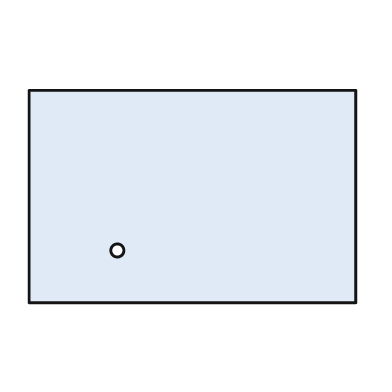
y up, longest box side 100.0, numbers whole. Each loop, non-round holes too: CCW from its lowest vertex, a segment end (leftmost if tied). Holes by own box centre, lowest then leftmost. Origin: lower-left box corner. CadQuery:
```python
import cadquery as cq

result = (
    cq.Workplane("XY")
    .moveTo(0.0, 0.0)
    .lineTo(100.0, 0.0)
    .lineTo(100.0, 65.0)
    .lineTo(0.0, 65.0)
    .close()
    .moveTo(27.0, 16.0)
    .circle(2.0)
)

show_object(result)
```